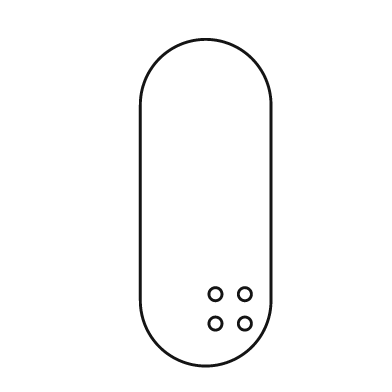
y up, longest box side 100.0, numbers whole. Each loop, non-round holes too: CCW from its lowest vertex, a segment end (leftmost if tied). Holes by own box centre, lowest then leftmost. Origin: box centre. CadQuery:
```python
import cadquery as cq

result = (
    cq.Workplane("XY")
    .moveTo(-20.0, -30.0)
    .threePointArc((0.0, -50.0), (20.0, -30.0))
    .lineTo(20.0, 30.0)
    .threePointArc((0.0, 50.0), (-20.0, 30.0))
    .close()
    .moveTo(3.0, -37.0)
    .circle(2.0)
    .moveTo(12.0, -37.0)
    .circle(2.0)
    .moveTo(3.0, -28.0)
    .circle(2.0)
    .moveTo(12.0, -28.0)
    .circle(2.0)
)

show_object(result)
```